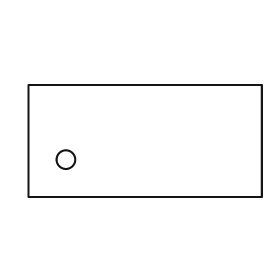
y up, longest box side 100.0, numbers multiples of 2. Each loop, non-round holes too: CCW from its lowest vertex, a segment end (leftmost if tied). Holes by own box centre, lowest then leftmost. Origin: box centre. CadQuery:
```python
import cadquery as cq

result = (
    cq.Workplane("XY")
    .moveTo(-50.0, -24.0)
    .lineTo(50.0, -24.0)
    .lineTo(50.0, 24.0)
    .lineTo(-50.0, 24.0)
    .close()
    .moveTo(-34.0, -8.0)
    .circle(4.0)
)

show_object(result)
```